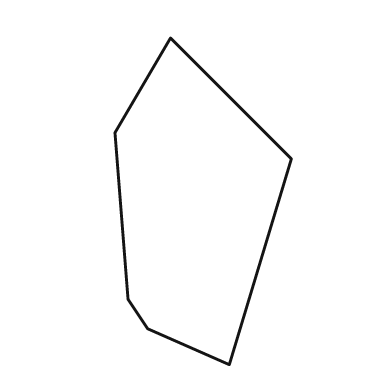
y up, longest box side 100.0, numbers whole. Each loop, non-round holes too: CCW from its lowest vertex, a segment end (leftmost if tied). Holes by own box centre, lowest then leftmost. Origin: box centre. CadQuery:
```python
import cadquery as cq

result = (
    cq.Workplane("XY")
    .moveTo(8.0, -50.0)
    .lineTo(27.0, 13.0)
    .lineTo(-10.0, 50.0)
    .lineTo(-27.0, 21.0)
    .lineTo(-23.0, -30.0)
    .lineTo(-17.0, -39.0)
    .close()
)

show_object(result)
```